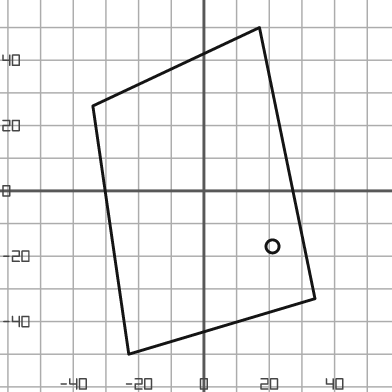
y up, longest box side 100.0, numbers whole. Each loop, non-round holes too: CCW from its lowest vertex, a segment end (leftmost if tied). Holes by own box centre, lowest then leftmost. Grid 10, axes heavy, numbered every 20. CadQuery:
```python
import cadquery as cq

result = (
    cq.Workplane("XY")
    .moveTo(-23.0, -50.0)
    .lineTo(34.0, -33.0)
    .lineTo(17.0, 50.0)
    .lineTo(-34.0, 26.0)
    .close()
    .moveTo(21.0, -17.0)
    .circle(2.0)
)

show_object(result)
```